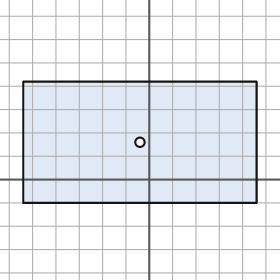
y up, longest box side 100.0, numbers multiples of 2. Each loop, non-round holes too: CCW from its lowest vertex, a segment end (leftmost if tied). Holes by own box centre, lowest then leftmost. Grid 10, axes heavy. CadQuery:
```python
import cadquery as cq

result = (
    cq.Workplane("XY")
    .moveTo(-54.0, -10.0)
    .lineTo(46.0, -10.0)
    .lineTo(46.0, 42.0)
    .lineTo(-54.0, 42.0)
    .close()
    .moveTo(-4.0, 16.0)
    .circle(2.0)
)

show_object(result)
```